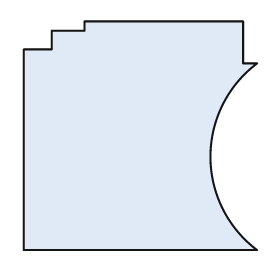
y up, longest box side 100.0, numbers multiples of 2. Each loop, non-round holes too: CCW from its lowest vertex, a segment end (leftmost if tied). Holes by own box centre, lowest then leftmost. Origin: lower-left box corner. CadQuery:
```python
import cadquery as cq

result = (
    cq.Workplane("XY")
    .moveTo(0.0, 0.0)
    .lineTo(100.0, 0.0)
    .threePointArc((80.0, 40.0), (100.0, 80.0))
    .lineTo(94.0, 80.0)
    .lineTo(94.0, 98.0)
    .lineTo(26.0, 98.0)
    .lineTo(26.0, 94.0)
    .lineTo(12.0, 94.0)
    .lineTo(12.0, 86.0)
    .lineTo(0.0, 86.0)
    .close()
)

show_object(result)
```